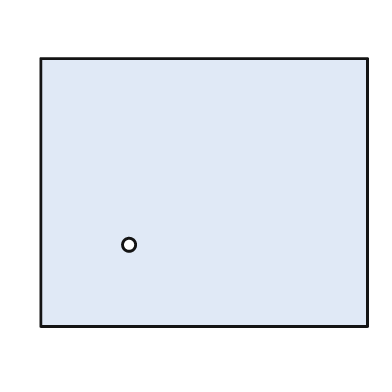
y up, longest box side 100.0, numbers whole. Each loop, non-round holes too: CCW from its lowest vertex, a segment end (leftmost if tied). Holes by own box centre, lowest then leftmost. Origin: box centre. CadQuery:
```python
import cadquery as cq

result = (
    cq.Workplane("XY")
    .moveTo(-50.0, -41.0)
    .lineTo(50.0, -41.0)
    .lineTo(50.0, 41.0)
    .lineTo(-50.0, 41.0)
    .close()
    .moveTo(-23.0, -16.0)
    .circle(2.0)
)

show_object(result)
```